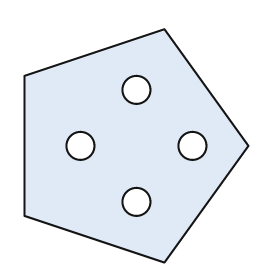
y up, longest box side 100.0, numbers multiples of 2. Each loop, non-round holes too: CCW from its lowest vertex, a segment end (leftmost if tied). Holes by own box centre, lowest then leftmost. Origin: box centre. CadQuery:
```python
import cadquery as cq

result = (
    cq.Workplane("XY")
    .moveTo(12.0, -50.0)
    .lineTo(48.0, 0.0)
    .lineTo(12.0, 50.0)
    .lineTo(-48.0, 30.0)
    .lineTo(-48.0, -30.0)
    .close()
    .moveTo(0.0, -24.0)
    .circle(6.0)
    .moveTo(-24.0, 0.0)
    .circle(6.0)
    .moveTo(24.0, 0.0)
    .circle(6.0)
    .moveTo(0.0, 24.0)
    .circle(6.0)
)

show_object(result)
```